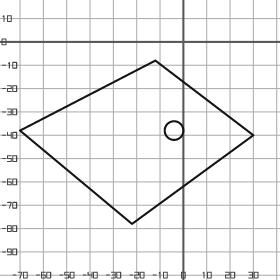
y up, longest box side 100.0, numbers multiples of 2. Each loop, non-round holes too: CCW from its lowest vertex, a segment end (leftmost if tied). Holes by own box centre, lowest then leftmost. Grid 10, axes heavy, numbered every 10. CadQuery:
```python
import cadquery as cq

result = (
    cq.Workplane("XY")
    .moveTo(-22.0, -78.0)
    .lineTo(30.0, -40.0)
    .lineTo(-12.0, -8.0)
    .lineTo(-70.0, -38.0)
    .close()
    .moveTo(-4.0, -38.0)
    .circle(4.0)
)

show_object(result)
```